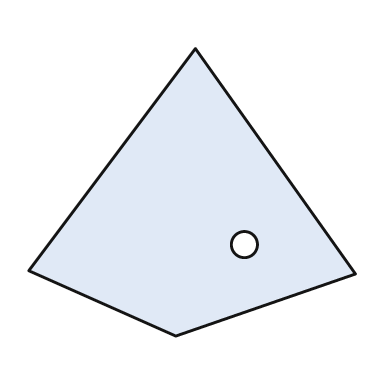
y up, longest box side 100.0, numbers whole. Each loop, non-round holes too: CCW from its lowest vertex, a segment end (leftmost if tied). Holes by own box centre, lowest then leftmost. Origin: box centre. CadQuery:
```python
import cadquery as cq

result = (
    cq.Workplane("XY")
    .moveTo(-5.0, -44.0)
    .lineTo(50.0, -25.0)
    .lineTo(1.0, 44.0)
    .lineTo(-50.0, -24.0)
    .close()
    .moveTo(16.0, -16.0)
    .circle(4.0)
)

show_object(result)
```